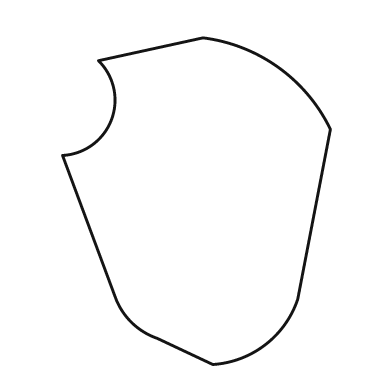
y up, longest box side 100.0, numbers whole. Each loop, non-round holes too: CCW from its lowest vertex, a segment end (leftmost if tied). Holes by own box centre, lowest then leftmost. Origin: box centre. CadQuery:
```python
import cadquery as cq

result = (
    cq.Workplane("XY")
    .moveTo(5.0, -50.0)
    .threePointArc((21.0, -44.0), (31.0, -30.0))
    .lineTo(41.0, 22.0)
    .threePointArc((25.0, 41.0), (2.0, 50.0))
    .lineTo(-30.0, 43.0)
    .threePointArc((-26.0, 25.0), (-41.0, 14.0))
    .lineTo(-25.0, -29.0)
    .threePointArc((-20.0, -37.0), (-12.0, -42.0))
    .close()
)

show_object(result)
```